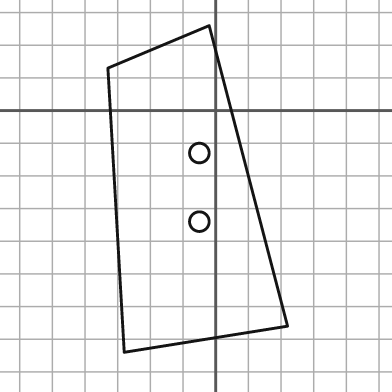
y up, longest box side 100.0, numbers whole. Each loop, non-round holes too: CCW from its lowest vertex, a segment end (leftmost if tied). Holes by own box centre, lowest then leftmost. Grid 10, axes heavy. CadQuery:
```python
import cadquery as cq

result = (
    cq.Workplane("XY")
    .moveTo(-28.0, -74.0)
    .lineTo(22.0, -66.0)
    .lineTo(-2.0, 26.0)
    .lineTo(-33.0, 13.0)
    .close()
    .moveTo(-5.0, -34.0)
    .circle(3.0)
    .moveTo(-5.0, -13.0)
    .circle(3.0)
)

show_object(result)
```